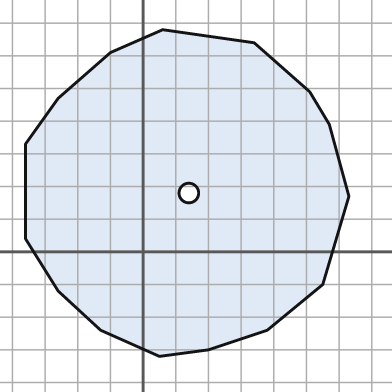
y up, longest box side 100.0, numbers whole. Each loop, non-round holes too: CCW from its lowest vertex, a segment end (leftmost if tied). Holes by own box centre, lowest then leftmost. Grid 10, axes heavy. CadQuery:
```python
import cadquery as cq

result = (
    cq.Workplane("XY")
    .moveTo(5.0, -32.0)
    .lineTo(20.0, -30.0)
    .lineTo(38.0, -24.0)
    .lineTo(55.0, -10.0)
    .lineTo(63.0, 17.0)
    .lineTo(57.0, 39.0)
    .lineTo(51.0, 49.0)
    .lineTo(34.0, 64.0)
    .lineTo(6.0, 68.0)
    .lineTo(-10.0, 61.0)
    .lineTo(-26.0, 47.0)
    .lineTo(-36.0, 33.0)
    .lineTo(-36.0, 4.0)
    .lineTo(-26.0, -12.0)
    .lineTo(-13.0, -24.0)
    .close()
    .moveTo(14.0, 18.0)
    .circle(3.0)
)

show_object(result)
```